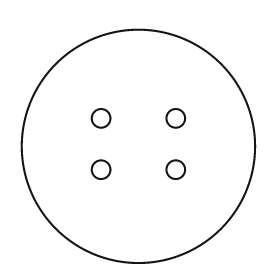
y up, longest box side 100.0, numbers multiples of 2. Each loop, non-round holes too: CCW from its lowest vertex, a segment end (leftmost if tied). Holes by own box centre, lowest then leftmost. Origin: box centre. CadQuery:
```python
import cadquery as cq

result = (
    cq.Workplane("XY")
    .moveTo(0.0, 0.0)
    .circle(50.0)
    .moveTo(-16.0, -10.0)
    .circle(4.0)
    .moveTo(16.0, -10.0)
    .circle(4.0)
    .moveTo(-16.0, 12.0)
    .circle(4.0)
    .moveTo(16.0, 12.0)
    .circle(4.0)
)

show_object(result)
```